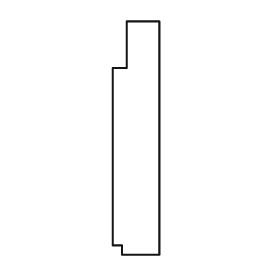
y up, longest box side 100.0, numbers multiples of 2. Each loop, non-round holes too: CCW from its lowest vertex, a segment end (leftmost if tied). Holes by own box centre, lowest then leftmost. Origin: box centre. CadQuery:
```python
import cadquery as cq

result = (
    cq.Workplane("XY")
    .moveTo(-6.0, -50.0)
    .lineTo(10.0, -50.0)
    .lineTo(10.0, 50.0)
    .lineTo(-4.0, 50.0)
    .lineTo(-4.0, 30.0)
    .lineTo(-10.0, 30.0)
    .lineTo(-10.0, -46.0)
    .lineTo(-6.0, -46.0)
    .close()
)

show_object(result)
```